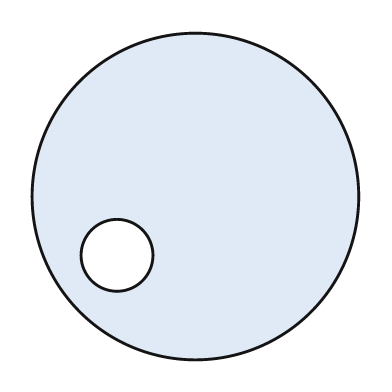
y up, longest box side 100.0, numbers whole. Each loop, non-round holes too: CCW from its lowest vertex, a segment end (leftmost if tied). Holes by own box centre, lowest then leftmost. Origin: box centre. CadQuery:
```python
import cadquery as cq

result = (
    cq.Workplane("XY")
    .moveTo(0.0, 0.0)
    .circle(50.0)
    .moveTo(-24.0, -18.0)
    .circle(11.0)
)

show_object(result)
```